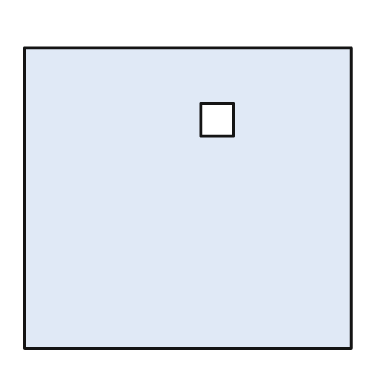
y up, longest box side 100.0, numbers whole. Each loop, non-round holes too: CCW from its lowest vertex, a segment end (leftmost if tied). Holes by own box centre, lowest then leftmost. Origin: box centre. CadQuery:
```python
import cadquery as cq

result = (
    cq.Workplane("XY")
    .moveTo(-50.0, -46.0)
    .lineTo(50.0, -46.0)
    .lineTo(50.0, 46.0)
    .lineTo(-50.0, 46.0)
    .close()
    .moveTo(4.0, 19.0)
    .lineTo(14.0, 19.0)
    .lineTo(14.0, 29.0)
    .lineTo(4.0, 29.0)
    .close()
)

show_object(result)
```